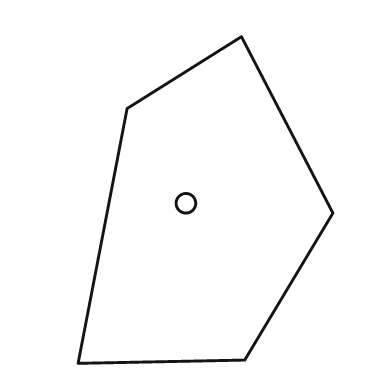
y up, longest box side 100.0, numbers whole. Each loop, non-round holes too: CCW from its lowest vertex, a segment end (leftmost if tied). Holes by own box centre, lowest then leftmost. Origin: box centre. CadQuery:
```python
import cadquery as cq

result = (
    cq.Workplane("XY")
    .moveTo(-39.0, -50.0)
    .lineTo(12.0, -49.0)
    .lineTo(39.0, -4.0)
    .lineTo(11.0, 50.0)
    .lineTo(-24.0, 28.0)
    .close()
    .moveTo(-6.0, -1.0)
    .circle(3.0)
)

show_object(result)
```